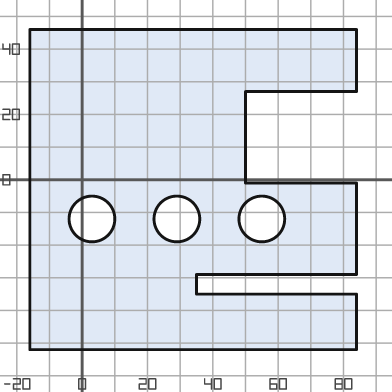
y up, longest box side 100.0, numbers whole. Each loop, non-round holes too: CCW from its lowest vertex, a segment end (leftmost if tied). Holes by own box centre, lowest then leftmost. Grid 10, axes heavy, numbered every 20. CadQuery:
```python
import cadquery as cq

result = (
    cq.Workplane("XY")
    .moveTo(-16.0, -52.0)
    .lineTo(84.0, -52.0)
    .lineTo(84.0, -35.0)
    .lineTo(35.0, -35.0)
    .lineTo(35.0, -29.0)
    .lineTo(84.0, -29.0)
    .lineTo(84.0, -1.0)
    .lineTo(50.0, -1.0)
    .lineTo(50.0, 27.0)
    .lineTo(84.0, 27.0)
    .lineTo(84.0, 46.0)
    .lineTo(-16.0, 46.0)
    .close()
    .moveTo(3.0, -12.0)
    .circle(7.0)
    .moveTo(29.0, -12.0)
    .circle(7.0)
    .moveTo(55.0, -12.0)
    .circle(7.0)
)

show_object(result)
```